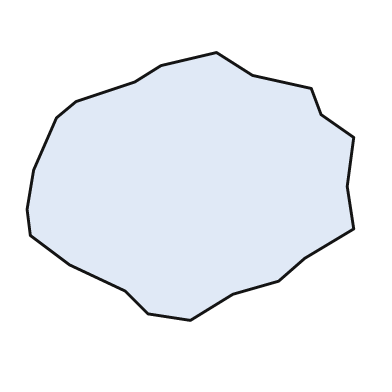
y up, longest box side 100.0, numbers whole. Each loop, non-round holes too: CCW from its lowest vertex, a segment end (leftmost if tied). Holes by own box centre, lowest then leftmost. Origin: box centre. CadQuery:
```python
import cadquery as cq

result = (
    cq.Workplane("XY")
    .moveTo(0.0, -41.0)
    .lineTo(13.0, -33.0)
    .lineTo(27.0, -29.0)
    .lineTo(35.0, -22.0)
    .lineTo(50.0, -13.0)
    .lineTo(48.0, 0.0)
    .lineTo(50.0, 15.0)
    .lineTo(40.0, 22.0)
    .lineTo(37.0, 30.0)
    .lineTo(19.0, 34.0)
    .lineTo(8.0, 41.0)
    .lineTo(-9.0, 37.0)
    .lineTo(-17.0, 32.0)
    .lineTo(-35.0, 26.0)
    .lineTo(-41.0, 21.0)
    .lineTo(-48.0, 5.0)
    .lineTo(-50.0, -7.0)
    .lineTo(-49.0, -15.0)
    .lineTo(-37.0, -24.0)
    .lineTo(-20.0, -32.0)
    .lineTo(-13.0, -39.0)
    .close()
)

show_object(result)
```